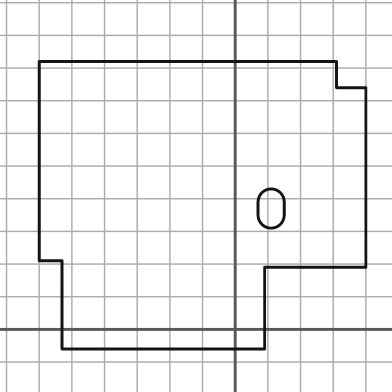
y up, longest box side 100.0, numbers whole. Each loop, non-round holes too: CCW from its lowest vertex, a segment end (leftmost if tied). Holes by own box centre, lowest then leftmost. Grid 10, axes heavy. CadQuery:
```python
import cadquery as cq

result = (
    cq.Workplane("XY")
    .moveTo(-53.0, -6.0)
    .lineTo(9.0, -6.0)
    .lineTo(9.0, 19.0)
    .lineTo(40.0, 19.0)
    .lineTo(40.0, 74.0)
    .lineTo(31.0, 74.0)
    .lineTo(31.0, 82.0)
    .lineTo(-60.0, 82.0)
    .lineTo(-60.0, 21.0)
    .lineTo(-53.0, 21.0)
    .close()
    .moveTo(7.0, 35.0)
    .threePointArc((11.0, 31.0), (15.0, 35.0))
    .lineTo(15.0, 39.0)
    .threePointArc((11.0, 43.0), (7.0, 39.0))
    .close()
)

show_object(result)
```